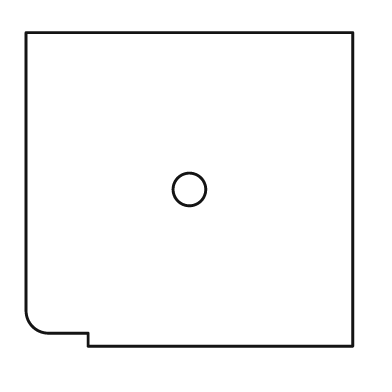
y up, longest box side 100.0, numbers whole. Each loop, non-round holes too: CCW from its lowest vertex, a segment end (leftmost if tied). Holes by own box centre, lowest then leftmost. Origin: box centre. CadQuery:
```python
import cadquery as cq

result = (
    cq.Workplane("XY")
    .moveTo(-31.0, -48.0)
    .lineTo(50.0, -48.0)
    .lineTo(50.0, 48.0)
    .lineTo(-50.0, 48.0)
    .lineTo(-50.0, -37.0)
    .threePointArc((-48.0, -42.0), (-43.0, -44.0))
    .lineTo(-31.0, -44.0)
    .close()
    .moveTo(0.0, 0.0)
    .circle(5.0)
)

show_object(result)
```